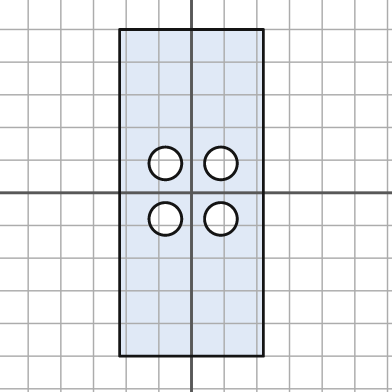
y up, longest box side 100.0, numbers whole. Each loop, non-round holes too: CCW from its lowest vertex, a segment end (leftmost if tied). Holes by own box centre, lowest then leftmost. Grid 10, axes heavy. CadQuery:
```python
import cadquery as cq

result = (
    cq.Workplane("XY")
    .moveTo(-22.0, -50.0)
    .lineTo(22.0, -50.0)
    .lineTo(22.0, 50.0)
    .lineTo(-22.0, 50.0)
    .close()
    .moveTo(-8.0, -8.0)
    .circle(5.0)
    .moveTo(9.0, -8.0)
    .circle(5.0)
    .moveTo(-8.0, 9.0)
    .circle(5.0)
    .moveTo(9.0, 9.0)
    .circle(5.0)
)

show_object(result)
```